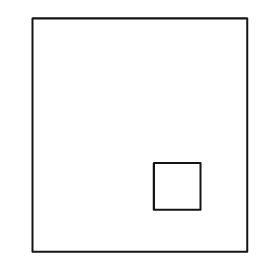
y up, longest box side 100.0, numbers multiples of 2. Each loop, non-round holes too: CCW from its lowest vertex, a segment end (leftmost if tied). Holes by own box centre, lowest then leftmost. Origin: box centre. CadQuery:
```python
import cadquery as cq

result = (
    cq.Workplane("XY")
    .moveTo(-46.0, -50.0)
    .lineTo(46.0, -50.0)
    .lineTo(46.0, 50.0)
    .lineTo(-46.0, 50.0)
    .close()
    .moveTo(6.0, -32.0)
    .lineTo(26.0, -32.0)
    .lineTo(26.0, -12.0)
    .lineTo(6.0, -12.0)
    .close()
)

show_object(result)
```